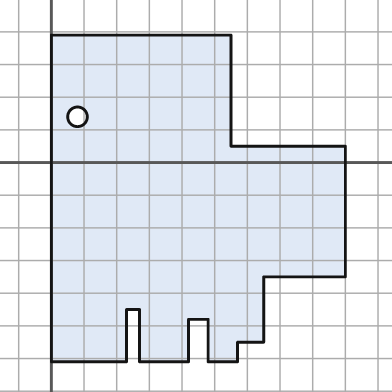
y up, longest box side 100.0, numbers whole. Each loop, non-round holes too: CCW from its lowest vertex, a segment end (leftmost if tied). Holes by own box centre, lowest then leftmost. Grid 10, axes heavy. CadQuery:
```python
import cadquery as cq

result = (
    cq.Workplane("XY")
    .moveTo(0.0, -61.0)
    .lineTo(23.0, -61.0)
    .lineTo(23.0, -45.0)
    .lineTo(27.0, -45.0)
    .lineTo(27.0, -61.0)
    .lineTo(42.0, -61.0)
    .lineTo(42.0, -48.0)
    .lineTo(48.0, -48.0)
    .lineTo(48.0, -61.0)
    .lineTo(57.0, -61.0)
    .lineTo(57.0, -55.0)
    .lineTo(65.0, -55.0)
    .lineTo(65.0, -35.0)
    .lineTo(90.0, -35.0)
    .lineTo(90.0, 5.0)
    .lineTo(55.0, 5.0)
    .lineTo(55.0, 39.0)
    .lineTo(0.0, 39.0)
    .close()
    .moveTo(8.0, 14.0)
    .circle(3.0)
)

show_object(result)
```